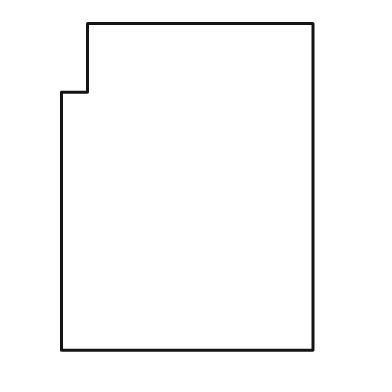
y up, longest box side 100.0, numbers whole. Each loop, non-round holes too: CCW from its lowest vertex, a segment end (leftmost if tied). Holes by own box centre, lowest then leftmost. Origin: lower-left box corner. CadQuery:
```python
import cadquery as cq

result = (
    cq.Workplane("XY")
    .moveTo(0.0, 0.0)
    .lineTo(77.0, 0.0)
    .lineTo(77.0, 100.0)
    .lineTo(8.0, 100.0)
    .lineTo(8.0, 79.0)
    .lineTo(0.0, 79.0)
    .close()
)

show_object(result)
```